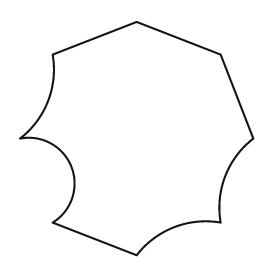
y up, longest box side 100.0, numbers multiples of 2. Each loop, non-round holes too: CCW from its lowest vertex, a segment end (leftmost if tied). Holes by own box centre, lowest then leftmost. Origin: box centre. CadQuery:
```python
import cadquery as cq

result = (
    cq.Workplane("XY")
    .moveTo(0.0, -50.0)
    .threePointArc((16.0, -38.0), (36.0, -36.0))
    .threePointArc((38.0, -16.0), (50.0, 0.0))
    .lineTo(36.0, 36.0)
    .lineTo(0.0, 50.0)
    .lineTo(-36.0, 36.0)
    .threePointArc((-38.0, 16.0), (-50.0, 0.0))
    .threePointArc((-28.0, -12.0), (-36.0, -36.0))
    .close()
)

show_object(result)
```